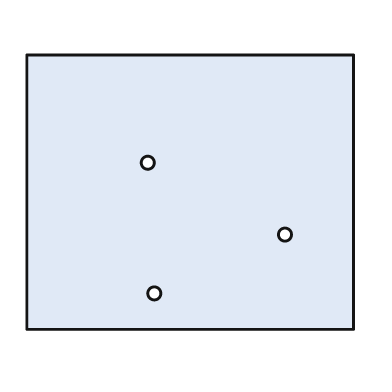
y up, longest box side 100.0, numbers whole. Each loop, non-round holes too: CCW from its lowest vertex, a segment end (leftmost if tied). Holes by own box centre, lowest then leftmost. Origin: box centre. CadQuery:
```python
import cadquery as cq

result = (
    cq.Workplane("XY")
    .moveTo(-50.0, -42.0)
    .lineTo(50.0, -42.0)
    .lineTo(50.0, 42.0)
    .lineTo(-50.0, 42.0)
    .close()
    .moveTo(-11.0, -31.0)
    .circle(2.0)
    .moveTo(29.0, -13.0)
    .circle(2.0)
    .moveTo(-13.0, 9.0)
    .circle(2.0)
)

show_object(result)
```